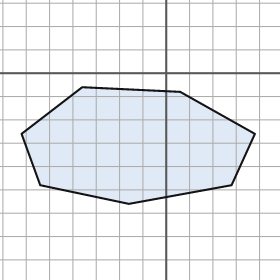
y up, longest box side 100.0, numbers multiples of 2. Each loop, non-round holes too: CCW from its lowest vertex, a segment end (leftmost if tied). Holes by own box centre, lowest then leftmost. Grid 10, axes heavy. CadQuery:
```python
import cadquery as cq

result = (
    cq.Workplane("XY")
    .moveTo(-16.0, -56.0)
    .lineTo(28.0, -48.0)
    .lineTo(38.0, -26.0)
    .lineTo(6.0, -8.0)
    .lineTo(-36.0, -6.0)
    .lineTo(-62.0, -26.0)
    .lineTo(-54.0, -48.0)
    .close()
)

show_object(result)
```